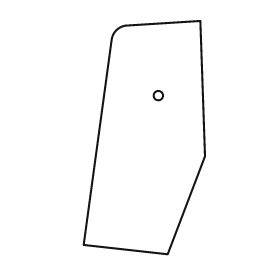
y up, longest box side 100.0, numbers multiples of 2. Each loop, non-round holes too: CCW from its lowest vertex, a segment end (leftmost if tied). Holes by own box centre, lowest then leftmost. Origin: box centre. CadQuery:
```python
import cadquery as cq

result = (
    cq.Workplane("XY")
    .moveTo(10.0, -50.0)
    .lineTo(26.0, -8.0)
    .lineTo(24.0, 50.0)
    .lineTo(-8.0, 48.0)
    .threePointArc((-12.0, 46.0), (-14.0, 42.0))
    .lineTo(-26.0, -46.0)
    .close()
    .moveTo(6.0, 18.0)
    .circle(2.0)
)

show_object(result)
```